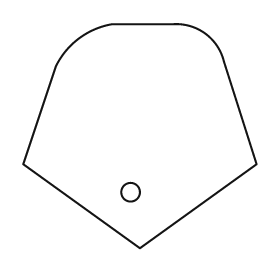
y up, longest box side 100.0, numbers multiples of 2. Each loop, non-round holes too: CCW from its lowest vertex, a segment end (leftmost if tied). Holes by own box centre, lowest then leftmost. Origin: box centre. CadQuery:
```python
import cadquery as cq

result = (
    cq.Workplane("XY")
    .moveTo(0.0, -48.0)
    .lineTo(50.0, -12.0)
    .lineTo(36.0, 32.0)
    .threePointArc((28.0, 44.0), (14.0, 48.0))
    .lineTo(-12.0, 48.0)
    .threePointArc((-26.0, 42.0), (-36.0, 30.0))
    .lineTo(-50.0, -12.0)
    .close()
    .moveTo(-4.0, -24.0)
    .circle(4.0)
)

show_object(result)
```